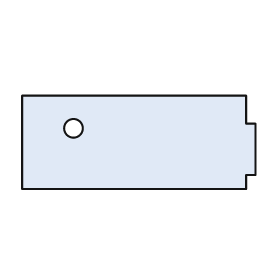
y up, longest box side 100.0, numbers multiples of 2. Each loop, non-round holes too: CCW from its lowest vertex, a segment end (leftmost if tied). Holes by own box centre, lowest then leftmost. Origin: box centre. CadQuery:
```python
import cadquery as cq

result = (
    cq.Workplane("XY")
    .moveTo(-50.0, -20.0)
    .lineTo(46.0, -20.0)
    .lineTo(46.0, -14.0)
    .lineTo(50.0, -14.0)
    .lineTo(50.0, 8.0)
    .lineTo(46.0, 8.0)
    .lineTo(46.0, 20.0)
    .lineTo(-50.0, 20.0)
    .close()
    .moveTo(-28.0, 6.0)
    .circle(4.0)
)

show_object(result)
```